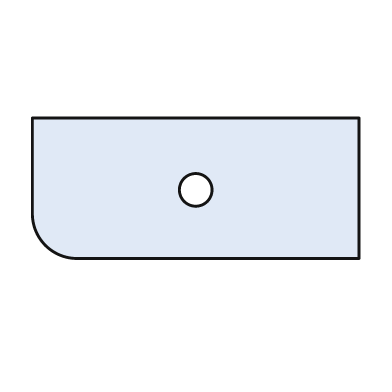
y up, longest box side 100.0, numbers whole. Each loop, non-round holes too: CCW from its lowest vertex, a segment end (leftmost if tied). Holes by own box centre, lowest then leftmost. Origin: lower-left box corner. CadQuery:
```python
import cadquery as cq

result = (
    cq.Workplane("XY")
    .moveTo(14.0, 0.0)
    .lineTo(100.0, 0.0)
    .lineTo(100.0, 43.0)
    .lineTo(0.0, 43.0)
    .lineTo(0.0, 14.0)
    .threePointArc((4.0, 4.0), (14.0, 0.0))
    .close()
    .moveTo(50.0, 21.0)
    .circle(5.0)
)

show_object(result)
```